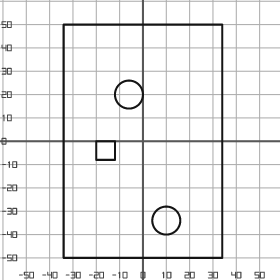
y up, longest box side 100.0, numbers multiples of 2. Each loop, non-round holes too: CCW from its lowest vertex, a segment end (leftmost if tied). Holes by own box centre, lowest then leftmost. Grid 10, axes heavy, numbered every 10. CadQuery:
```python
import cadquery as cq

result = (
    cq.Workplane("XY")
    .moveTo(-34.0, -50.0)
    .lineTo(34.0, -50.0)
    .lineTo(34.0, 50.0)
    .lineTo(-34.0, 50.0)
    .close()
    .moveTo(10.0, -34.0)
    .circle(6.0)
    .moveTo(-20.0, -8.0)
    .lineTo(-12.0, -8.0)
    .lineTo(-12.0, 0.0)
    .lineTo(-20.0, 0.0)
    .close()
    .moveTo(-6.0, 20.0)
    .circle(6.0)
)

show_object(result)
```